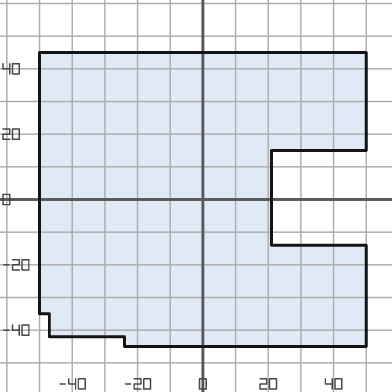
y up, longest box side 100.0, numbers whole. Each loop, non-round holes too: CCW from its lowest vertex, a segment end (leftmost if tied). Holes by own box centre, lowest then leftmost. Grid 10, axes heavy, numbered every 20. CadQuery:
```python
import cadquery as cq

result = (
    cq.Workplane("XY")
    .moveTo(-24.0, -45.0)
    .lineTo(50.0, -45.0)
    .lineTo(50.0, -14.0)
    .lineTo(21.0, -14.0)
    .lineTo(21.0, 15.0)
    .lineTo(50.0, 15.0)
    .lineTo(50.0, 45.0)
    .lineTo(-50.0, 45.0)
    .lineTo(-50.0, -35.0)
    .lineTo(-47.0, -35.0)
    .lineTo(-47.0, -42.0)
    .lineTo(-24.0, -42.0)
    .close()
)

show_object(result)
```